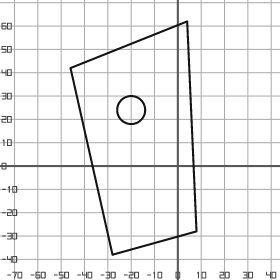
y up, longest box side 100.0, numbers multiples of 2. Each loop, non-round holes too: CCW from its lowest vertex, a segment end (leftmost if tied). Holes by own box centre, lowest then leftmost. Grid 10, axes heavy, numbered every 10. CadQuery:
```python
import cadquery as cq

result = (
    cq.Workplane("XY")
    .moveTo(-28.0, -38.0)
    .lineTo(8.0, -28.0)
    .lineTo(4.0, 62.0)
    .lineTo(-46.0, 42.0)
    .close()
    .moveTo(-20.0, 24.0)
    .circle(6.0)
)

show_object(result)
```